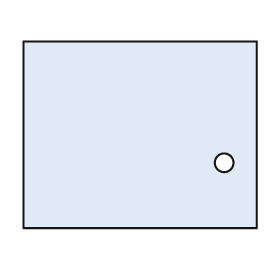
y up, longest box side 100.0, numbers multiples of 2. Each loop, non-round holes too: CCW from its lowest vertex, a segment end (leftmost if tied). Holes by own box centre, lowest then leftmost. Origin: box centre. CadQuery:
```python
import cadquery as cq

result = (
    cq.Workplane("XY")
    .moveTo(-50.0, -40.0)
    .lineTo(50.0, -40.0)
    .lineTo(50.0, 40.0)
    .lineTo(-50.0, 40.0)
    .close()
    .moveTo(36.0, -12.0)
    .circle(4.0)
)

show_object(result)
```